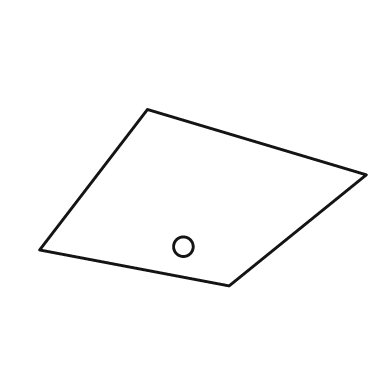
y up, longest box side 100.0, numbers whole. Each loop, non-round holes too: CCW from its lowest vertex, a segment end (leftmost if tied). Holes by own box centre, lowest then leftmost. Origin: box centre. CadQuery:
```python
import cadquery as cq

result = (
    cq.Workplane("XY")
    .moveTo(8.0, -27.0)
    .lineTo(50.0, 7.0)
    .lineTo(-17.0, 27.0)
    .lineTo(-50.0, -16.0)
    .close()
    .moveTo(-6.0, -15.0)
    .circle(3.0)
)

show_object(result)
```